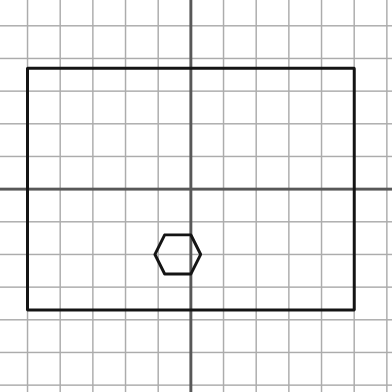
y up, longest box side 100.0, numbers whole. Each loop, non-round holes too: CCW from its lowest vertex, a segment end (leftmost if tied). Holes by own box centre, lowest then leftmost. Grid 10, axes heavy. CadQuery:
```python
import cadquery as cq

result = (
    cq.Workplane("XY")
    .moveTo(-50.0, -37.0)
    .lineTo(50.0, -37.0)
    .lineTo(50.0, 37.0)
    .lineTo(-50.0, 37.0)
    .close()
    .moveTo(-8.0, -26.0)
    .lineTo(0.0, -26.0)
    .lineTo(3.0, -20.0)
    .lineTo(0.0, -14.0)
    .lineTo(-8.0, -14.0)
    .lineTo(-11.0, -20.0)
    .close()
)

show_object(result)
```